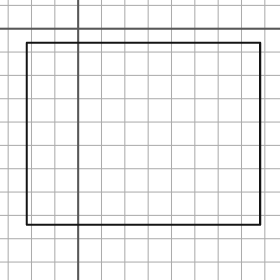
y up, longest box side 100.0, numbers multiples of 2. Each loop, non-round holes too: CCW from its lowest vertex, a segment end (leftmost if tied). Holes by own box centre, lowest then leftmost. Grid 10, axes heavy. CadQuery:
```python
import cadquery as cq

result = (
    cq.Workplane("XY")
    .moveTo(-22.0, -84.0)
    .lineTo(78.0, -84.0)
    .lineTo(78.0, -6.0)
    .lineTo(-22.0, -6.0)
    .close()
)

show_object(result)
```